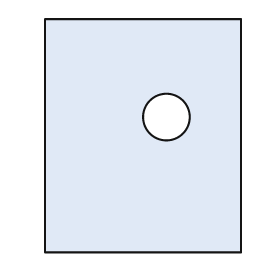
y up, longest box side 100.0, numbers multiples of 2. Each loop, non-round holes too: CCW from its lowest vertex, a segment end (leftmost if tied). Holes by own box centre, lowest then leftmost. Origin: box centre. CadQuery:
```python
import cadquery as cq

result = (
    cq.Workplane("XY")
    .moveTo(-42.0, -50.0)
    .lineTo(42.0, -50.0)
    .lineTo(42.0, 50.0)
    .lineTo(-42.0, 50.0)
    .close()
    .moveTo(10.0, 8.0)
    .circle(10.0)
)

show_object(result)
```